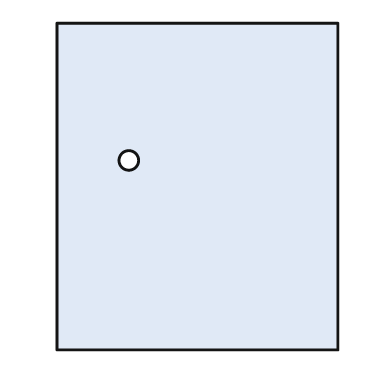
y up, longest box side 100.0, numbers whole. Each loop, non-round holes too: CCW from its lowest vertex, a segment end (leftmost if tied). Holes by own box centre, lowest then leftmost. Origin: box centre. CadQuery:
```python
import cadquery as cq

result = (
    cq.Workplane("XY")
    .moveTo(-43.0, -50.0)
    .lineTo(43.0, -50.0)
    .lineTo(43.0, 50.0)
    .lineTo(-43.0, 50.0)
    .close()
    .moveTo(-21.0, 8.0)
    .circle(3.0)
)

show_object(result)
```